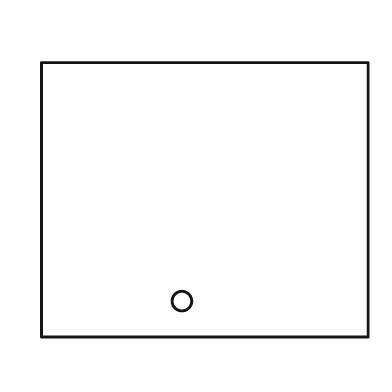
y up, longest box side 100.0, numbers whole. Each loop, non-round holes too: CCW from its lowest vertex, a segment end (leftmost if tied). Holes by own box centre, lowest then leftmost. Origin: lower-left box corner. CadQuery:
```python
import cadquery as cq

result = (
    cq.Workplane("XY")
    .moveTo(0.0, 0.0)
    .lineTo(100.0, 0.0)
    .lineTo(100.0, 84.0)
    .lineTo(0.0, 84.0)
    .close()
    .moveTo(43.0, 11.0)
    .circle(3.0)
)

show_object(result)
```